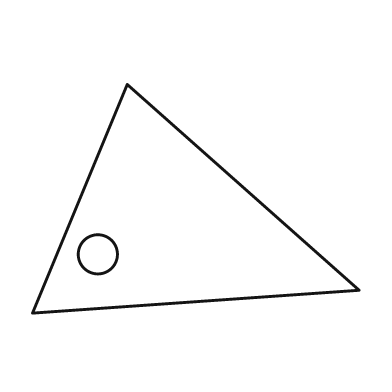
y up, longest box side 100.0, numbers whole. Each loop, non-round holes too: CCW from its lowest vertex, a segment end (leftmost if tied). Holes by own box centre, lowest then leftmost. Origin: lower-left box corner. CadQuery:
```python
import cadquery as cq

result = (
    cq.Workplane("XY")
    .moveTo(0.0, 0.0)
    .lineTo(100.0, 7.0)
    .lineTo(29.0, 70.0)
    .close()
    .moveTo(20.0, 18.0)
    .circle(6.0)
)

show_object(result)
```